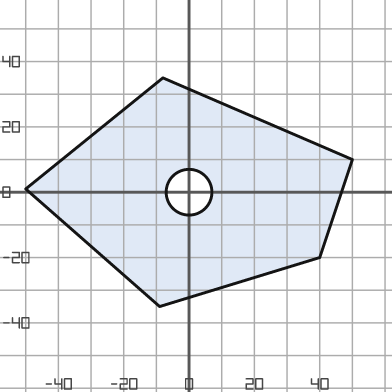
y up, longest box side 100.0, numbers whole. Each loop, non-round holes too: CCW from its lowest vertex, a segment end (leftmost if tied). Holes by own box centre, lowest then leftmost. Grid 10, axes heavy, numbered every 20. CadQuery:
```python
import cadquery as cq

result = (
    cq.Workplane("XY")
    .moveTo(-9.0, -35.0)
    .lineTo(40.0, -20.0)
    .lineTo(50.0, 10.0)
    .lineTo(-8.0, 35.0)
    .lineTo(-50.0, 1.0)
    .close()
    .moveTo(0.0, 0.0)
    .circle(7.0)
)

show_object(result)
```